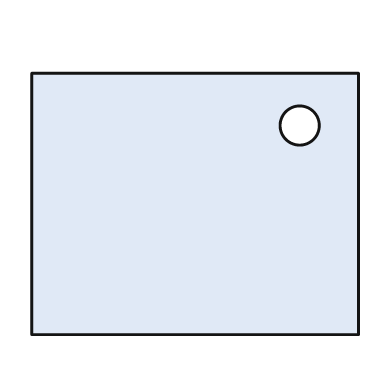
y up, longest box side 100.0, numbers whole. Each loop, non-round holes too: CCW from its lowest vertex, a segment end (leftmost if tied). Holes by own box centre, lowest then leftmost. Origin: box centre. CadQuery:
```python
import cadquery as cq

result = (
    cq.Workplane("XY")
    .moveTo(-50.0, -40.0)
    .lineTo(50.0, -40.0)
    .lineTo(50.0, 40.0)
    .lineTo(-50.0, 40.0)
    .close()
    .moveTo(32.0, 24.0)
    .circle(6.0)
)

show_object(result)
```